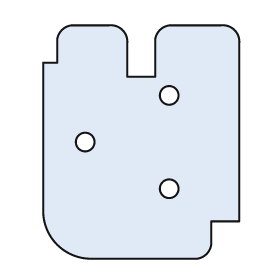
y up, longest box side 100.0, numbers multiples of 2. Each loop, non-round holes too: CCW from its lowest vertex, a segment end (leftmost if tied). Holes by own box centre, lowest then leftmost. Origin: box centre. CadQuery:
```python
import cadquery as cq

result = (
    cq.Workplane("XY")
    .moveTo(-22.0, -50.0)
    .lineTo(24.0, -50.0)
    .threePointArc((28.0, -48.0), (30.0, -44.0))
    .lineTo(30.0, -34.0)
    .lineTo(42.0, -34.0)
    .lineTo(42.0, 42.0)
    .threePointArc((40.0, 48.0), (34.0, 50.0))
    .lineTo(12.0, 50.0)
    .threePointArc((8.0, 48.0), (6.0, 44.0))
    .lineTo(6.0, 28.0)
    .lineTo(-6.0, 28.0)
    .lineTo(-6.0, 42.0)
    .threePointArc((-8.0, 48.0), (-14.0, 50.0))
    .lineTo(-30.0, 50.0)
    .threePointArc((-34.0, 48.0), (-36.0, 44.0))
    .lineTo(-36.0, 34.0)
    .lineTo(-42.0, 34.0)
    .lineTo(-42.0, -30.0)
    .threePointArc((-36.0, -44.0), (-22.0, -50.0))
    .close()
    .moveTo(12.0, -20.0)
    .circle(4.0)
    .moveTo(-24.0, 0.0)
    .circle(4.0)
    .moveTo(12.0, 20.0)
    .circle(4.0)
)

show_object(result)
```